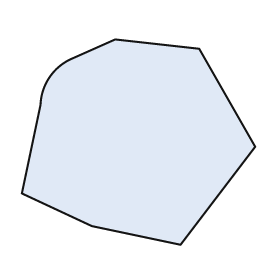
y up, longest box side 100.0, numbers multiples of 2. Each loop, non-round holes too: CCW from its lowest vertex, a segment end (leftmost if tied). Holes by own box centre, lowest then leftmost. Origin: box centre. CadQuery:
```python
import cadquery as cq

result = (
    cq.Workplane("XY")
    .moveTo(18.0, -44.0)
    .lineTo(50.0, -2.0)
    .lineTo(26.0, 40.0)
    .lineTo(-10.0, 44.0)
    .lineTo(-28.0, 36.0)
    .threePointArc((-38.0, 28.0), (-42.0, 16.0))
    .lineTo(-50.0, -22.0)
    .lineTo(-20.0, -36.0)
    .close()
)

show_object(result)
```